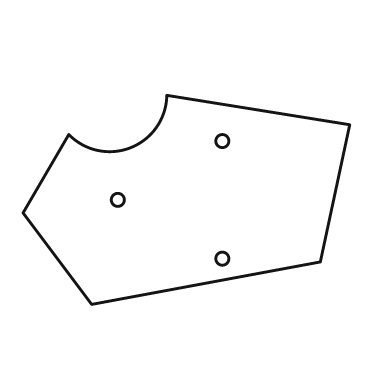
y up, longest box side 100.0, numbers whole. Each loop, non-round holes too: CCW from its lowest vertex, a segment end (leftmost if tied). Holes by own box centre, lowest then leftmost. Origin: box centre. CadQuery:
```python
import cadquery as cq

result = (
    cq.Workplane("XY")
    .moveTo(-29.0, -32.0)
    .lineTo(41.0, -19.0)
    .lineTo(50.0, 23.0)
    .lineTo(-6.0, 32.0)
    .threePointArc((-17.0, 16.0), (-36.0, 20.0))
    .lineTo(-50.0, -4.0)
    .close()
    .moveTo(11.0, -18.0)
    .circle(2.0)
    .moveTo(-21.0, 0.0)
    .circle(2.0)
    .moveTo(11.0, 18.0)
    .circle(2.0)
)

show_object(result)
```